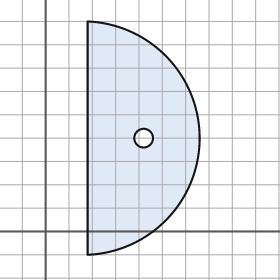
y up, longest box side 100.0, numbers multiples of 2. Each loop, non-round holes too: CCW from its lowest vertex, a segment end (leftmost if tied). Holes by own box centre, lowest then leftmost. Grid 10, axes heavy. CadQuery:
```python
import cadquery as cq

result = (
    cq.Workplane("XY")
    .moveTo(18.0, -10.0)
    .threePointArc((66.0, 40.0), (18.0, 90.0))
    .close()
    .moveTo(42.0, 40.0)
    .circle(4.0)
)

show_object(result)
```